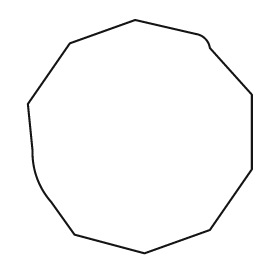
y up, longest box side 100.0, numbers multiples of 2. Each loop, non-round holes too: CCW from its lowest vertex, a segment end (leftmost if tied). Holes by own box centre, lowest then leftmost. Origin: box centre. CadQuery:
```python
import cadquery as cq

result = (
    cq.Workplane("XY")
    .moveTo(2.0, -50.0)
    .lineTo(30.0, -40.0)
    .lineTo(48.0, -14.0)
    .lineTo(48.0, 18.0)
    .lineTo(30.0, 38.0)
    .threePointArc((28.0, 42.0), (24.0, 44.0))
    .lineTo(-2.0, 50.0)
    .lineTo(-30.0, 40.0)
    .lineTo(-48.0, 14.0)
    .lineTo(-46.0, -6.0)
    .threePointArc((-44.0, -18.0), (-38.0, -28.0))
    .lineTo(-28.0, -42.0)
    .close()
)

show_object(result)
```